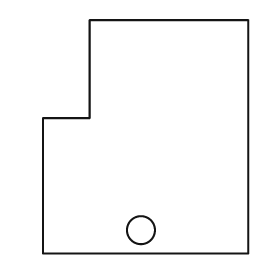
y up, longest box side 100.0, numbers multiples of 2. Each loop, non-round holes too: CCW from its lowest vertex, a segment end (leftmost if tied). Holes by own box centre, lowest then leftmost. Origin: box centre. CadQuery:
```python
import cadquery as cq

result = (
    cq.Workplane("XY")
    .moveTo(-44.0, -50.0)
    .lineTo(44.0, -50.0)
    .lineTo(44.0, 50.0)
    .lineTo(-24.0, 50.0)
    .lineTo(-24.0, 8.0)
    .lineTo(-44.0, 8.0)
    .close()
    .moveTo(-2.0, -40.0)
    .circle(6.0)
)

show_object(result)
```